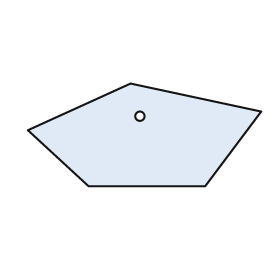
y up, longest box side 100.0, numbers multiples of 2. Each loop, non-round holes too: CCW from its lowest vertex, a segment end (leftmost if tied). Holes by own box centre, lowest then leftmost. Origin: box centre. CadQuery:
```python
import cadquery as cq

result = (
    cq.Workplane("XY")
    .moveTo(-24.0, -22.0)
    .lineTo(26.0, -22.0)
    .lineTo(50.0, 10.0)
    .lineTo(-6.0, 22.0)
    .lineTo(-50.0, 2.0)
    .close()
    .moveTo(-2.0, 8.0)
    .circle(2.0)
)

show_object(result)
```